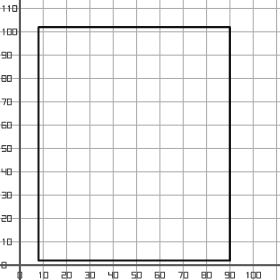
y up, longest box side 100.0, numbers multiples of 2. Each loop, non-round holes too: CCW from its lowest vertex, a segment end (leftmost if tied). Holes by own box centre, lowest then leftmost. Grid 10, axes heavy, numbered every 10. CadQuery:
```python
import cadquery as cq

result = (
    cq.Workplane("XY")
    .moveTo(8.0, 2.0)
    .lineTo(90.0, 2.0)
    .lineTo(90.0, 102.0)
    .lineTo(8.0, 102.0)
    .close()
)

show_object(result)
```